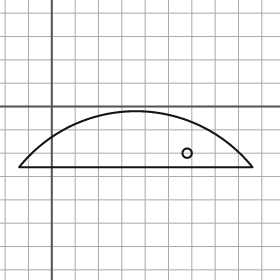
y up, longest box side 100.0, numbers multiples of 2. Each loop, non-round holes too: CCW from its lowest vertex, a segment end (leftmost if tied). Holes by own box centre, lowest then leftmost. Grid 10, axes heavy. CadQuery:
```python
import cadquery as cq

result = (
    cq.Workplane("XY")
    .moveTo(-14.0, -26.0)
    .lineTo(86.0, -26.0)
    .threePointArc((36.0, -2.0), (-14.0, -26.0))
    .close()
    .moveTo(58.0, -20.0)
    .circle(2.0)
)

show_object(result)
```